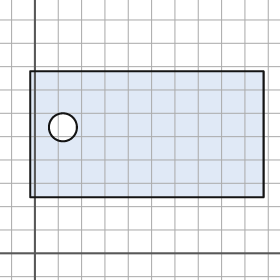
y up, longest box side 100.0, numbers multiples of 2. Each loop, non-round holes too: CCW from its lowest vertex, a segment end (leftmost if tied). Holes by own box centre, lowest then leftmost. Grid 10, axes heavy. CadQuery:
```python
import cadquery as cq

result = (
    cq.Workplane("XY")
    .moveTo(-2.0, 24.0)
    .lineTo(98.0, 24.0)
    .lineTo(98.0, 78.0)
    .lineTo(-2.0, 78.0)
    .close()
    .moveTo(12.0, 54.0)
    .circle(6.0)
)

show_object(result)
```